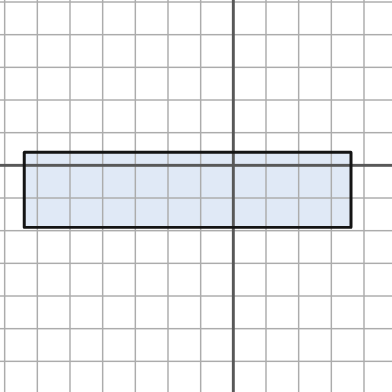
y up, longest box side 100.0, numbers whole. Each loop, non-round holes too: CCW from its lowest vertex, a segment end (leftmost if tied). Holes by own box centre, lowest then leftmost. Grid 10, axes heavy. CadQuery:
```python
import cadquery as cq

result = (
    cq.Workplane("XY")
    .moveTo(-64.0, -19.0)
    .lineTo(36.0, -19.0)
    .lineTo(36.0, 4.0)
    .lineTo(-64.0, 4.0)
    .close()
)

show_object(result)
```